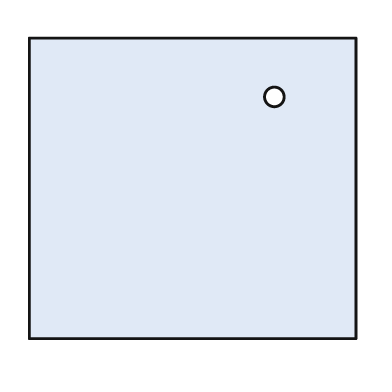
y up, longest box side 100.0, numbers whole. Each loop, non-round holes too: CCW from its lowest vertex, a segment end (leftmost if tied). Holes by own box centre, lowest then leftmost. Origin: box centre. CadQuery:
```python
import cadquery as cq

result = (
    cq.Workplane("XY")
    .moveTo(-50.0, -46.0)
    .lineTo(50.0, -46.0)
    .lineTo(50.0, 46.0)
    .lineTo(-50.0, 46.0)
    .close()
    .moveTo(25.0, 28.0)
    .circle(3.0)
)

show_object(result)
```